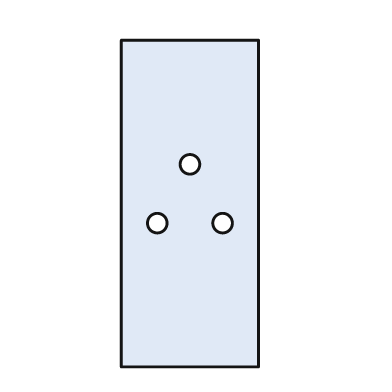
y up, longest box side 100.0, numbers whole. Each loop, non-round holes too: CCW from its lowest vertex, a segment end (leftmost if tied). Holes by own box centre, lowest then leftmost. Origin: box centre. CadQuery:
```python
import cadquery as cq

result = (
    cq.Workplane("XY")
    .moveTo(-21.0, -50.0)
    .lineTo(21.0, -50.0)
    .lineTo(21.0, 50.0)
    .lineTo(-21.0, 50.0)
    .close()
    .moveTo(-10.0, -6.0)
    .circle(3.0)
    .moveTo(10.0, -6.0)
    .circle(3.0)
    .moveTo(0.0, 12.0)
    .circle(3.0)
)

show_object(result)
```